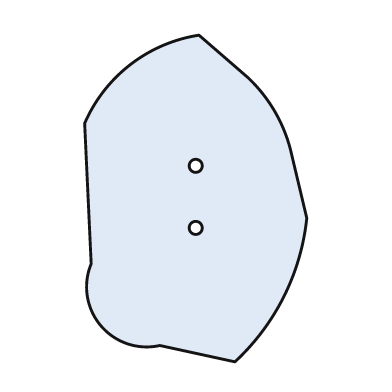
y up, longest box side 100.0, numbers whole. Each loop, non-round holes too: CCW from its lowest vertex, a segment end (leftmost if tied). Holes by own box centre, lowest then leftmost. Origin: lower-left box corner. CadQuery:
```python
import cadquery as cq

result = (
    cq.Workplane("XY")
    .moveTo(46.0, 0.0)
    .threePointArc((61.0, 20.0), (68.0, 44.0))
    .lineTo(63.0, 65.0)
    .threePointArc((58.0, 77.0), (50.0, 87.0))
    .lineTo(35.0, 100.0)
    .threePointArc((14.0, 91.0), (0.0, 73.0))
    .lineTo(2.0, 30.0)
    .threePointArc((5.0, 11.0), (23.0, 5.0))
    .close()
    .moveTo(34.0, 41.0)
    .circle(2.0)
    .moveTo(34.0, 60.0)
    .circle(2.0)
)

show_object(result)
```